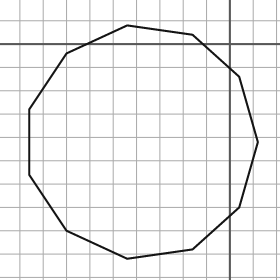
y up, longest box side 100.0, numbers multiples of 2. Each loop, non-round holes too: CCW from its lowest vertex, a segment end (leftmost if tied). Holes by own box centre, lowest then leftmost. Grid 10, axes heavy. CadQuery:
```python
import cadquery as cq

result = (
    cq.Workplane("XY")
    .moveTo(-44.0, -92.0)
    .lineTo(-16.0, -88.0)
    .lineTo(4.0, -70.0)
    .lineTo(12.0, -42.0)
    .lineTo(4.0, -14.0)
    .lineTo(-16.0, 4.0)
    .lineTo(-44.0, 8.0)
    .lineTo(-70.0, -4.0)
    .lineTo(-86.0, -28.0)
    .lineTo(-86.0, -56.0)
    .lineTo(-70.0, -80.0)
    .close()
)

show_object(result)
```